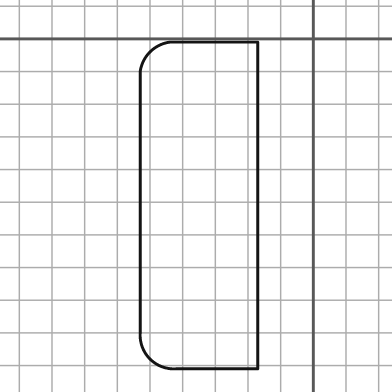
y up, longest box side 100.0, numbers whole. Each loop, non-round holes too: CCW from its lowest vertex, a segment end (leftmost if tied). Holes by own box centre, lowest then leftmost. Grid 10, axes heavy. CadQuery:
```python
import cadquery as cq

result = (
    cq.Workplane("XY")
    .moveTo(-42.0, -101.0)
    .lineTo(-17.0, -101.0)
    .lineTo(-17.0, -1.0)
    .lineTo(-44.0, -1.0)
    .threePointArc((-50.0, -4.0), (-53.0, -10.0))
    .lineTo(-53.0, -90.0)
    .threePointArc((-50.0, -98.0), (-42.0, -101.0))
    .close()
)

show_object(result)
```